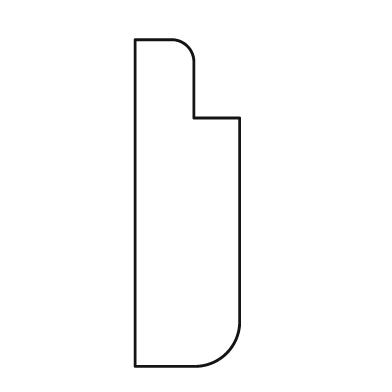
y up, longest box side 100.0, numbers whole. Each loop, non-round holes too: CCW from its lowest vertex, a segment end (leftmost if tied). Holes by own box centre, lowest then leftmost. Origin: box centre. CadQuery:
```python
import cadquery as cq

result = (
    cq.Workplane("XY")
    .moveTo(-16.0, -50.0)
    .lineTo(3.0, -50.0)
    .threePointArc((12.0, -46.0), (16.0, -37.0))
    .lineTo(16.0, 26.0)
    .lineTo(2.0, 26.0)
    .lineTo(2.0, 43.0)
    .threePointArc((0.0, 48.0), (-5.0, 50.0))
    .lineTo(-16.0, 50.0)
    .close()
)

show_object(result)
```